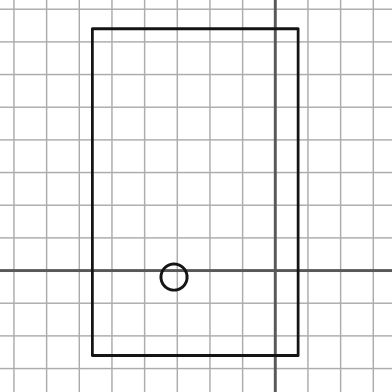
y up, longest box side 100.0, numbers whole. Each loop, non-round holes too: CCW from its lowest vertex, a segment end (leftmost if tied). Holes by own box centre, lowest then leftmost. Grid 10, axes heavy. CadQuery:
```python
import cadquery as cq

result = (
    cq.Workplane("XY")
    .moveTo(-56.0, -26.0)
    .lineTo(7.0, -26.0)
    .lineTo(7.0, 74.0)
    .lineTo(-56.0, 74.0)
    .close()
    .moveTo(-31.0, -2.0)
    .circle(4.0)
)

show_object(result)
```